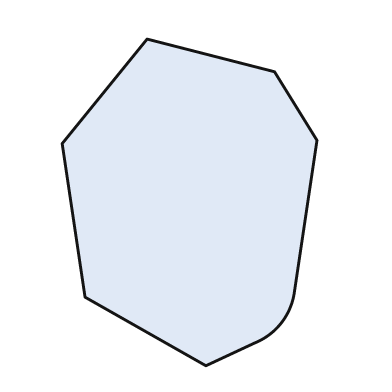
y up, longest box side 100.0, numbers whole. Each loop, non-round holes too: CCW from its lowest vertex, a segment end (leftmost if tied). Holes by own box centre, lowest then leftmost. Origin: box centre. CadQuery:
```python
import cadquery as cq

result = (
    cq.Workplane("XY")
    .moveTo(5.0, -50.0)
    .lineTo(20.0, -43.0)
    .threePointArc((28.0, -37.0), (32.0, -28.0))
    .lineTo(39.0, 19.0)
    .lineTo(26.0, 40.0)
    .lineTo(-13.0, 50.0)
    .lineTo(-39.0, 18.0)
    .lineTo(-32.0, -29.0)
    .close()
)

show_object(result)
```